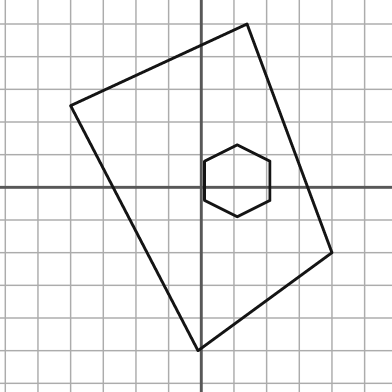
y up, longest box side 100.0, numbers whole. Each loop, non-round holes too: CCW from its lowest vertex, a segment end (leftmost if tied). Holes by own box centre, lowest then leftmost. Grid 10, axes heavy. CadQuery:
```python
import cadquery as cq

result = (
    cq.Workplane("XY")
    .moveTo(-1.0, -50.0)
    .lineTo(40.0, -20.0)
    .lineTo(14.0, 50.0)
    .lineTo(-40.0, 25.0)
    .close()
    .moveTo(11.0, -9.0)
    .lineTo(21.0, -4.0)
    .lineTo(21.0, 8.0)
    .lineTo(11.0, 13.0)
    .lineTo(1.0, 8.0)
    .lineTo(1.0, -4.0)
    .close()
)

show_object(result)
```